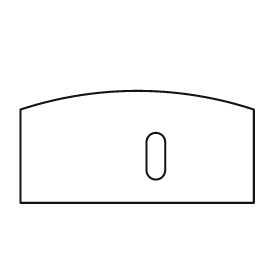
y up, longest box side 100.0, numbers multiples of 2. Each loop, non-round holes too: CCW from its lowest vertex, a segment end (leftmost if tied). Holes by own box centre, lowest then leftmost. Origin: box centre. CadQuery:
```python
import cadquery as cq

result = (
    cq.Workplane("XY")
    .moveTo(-50.0, -24.0)
    .lineTo(50.0, -24.0)
    .lineTo(50.0, 16.0)
    .threePointArc((0.0, 24.0), (-50.0, 16.0))
    .close()
    .moveTo(4.0, -10.0)
    .threePointArc((8.0, -14.0), (12.0, -10.0))
    .lineTo(12.0, 2.0)
    .threePointArc((8.0, 6.0), (4.0, 2.0))
    .close()
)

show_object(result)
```